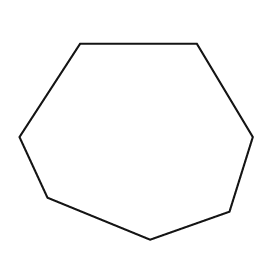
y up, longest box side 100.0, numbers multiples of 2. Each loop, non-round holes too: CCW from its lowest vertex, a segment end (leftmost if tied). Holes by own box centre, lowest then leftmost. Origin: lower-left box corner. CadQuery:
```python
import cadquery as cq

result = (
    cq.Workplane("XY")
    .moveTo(56.0, 0.0)
    .lineTo(90.0, 12.0)
    .lineTo(100.0, 44.0)
    .lineTo(76.0, 84.0)
    .lineTo(26.0, 84.0)
    .lineTo(0.0, 44.0)
    .lineTo(12.0, 18.0)
    .close()
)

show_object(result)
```